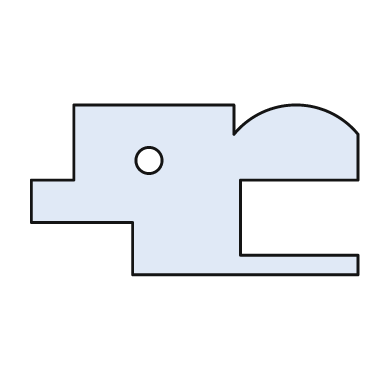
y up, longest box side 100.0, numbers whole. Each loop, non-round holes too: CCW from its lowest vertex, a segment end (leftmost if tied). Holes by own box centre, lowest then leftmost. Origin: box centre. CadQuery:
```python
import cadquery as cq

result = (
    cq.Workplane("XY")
    .moveTo(-19.0, -26.0)
    .lineTo(50.0, -26.0)
    .lineTo(50.0, -20.0)
    .lineTo(14.0, -20.0)
    .lineTo(14.0, 3.0)
    .lineTo(50.0, 3.0)
    .lineTo(50.0, 17.0)
    .threePointArc((31.0, 26.0), (12.0, 17.0))
    .lineTo(12.0, 26.0)
    .lineTo(-37.0, 26.0)
    .lineTo(-37.0, 3.0)
    .lineTo(-50.0, 3.0)
    .lineTo(-50.0, -10.0)
    .lineTo(-19.0, -10.0)
    .close()
    .moveTo(-14.0, 9.0)
    .circle(4.0)
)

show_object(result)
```